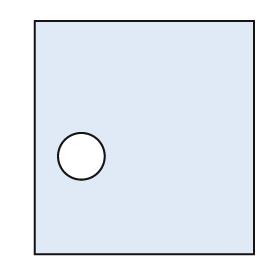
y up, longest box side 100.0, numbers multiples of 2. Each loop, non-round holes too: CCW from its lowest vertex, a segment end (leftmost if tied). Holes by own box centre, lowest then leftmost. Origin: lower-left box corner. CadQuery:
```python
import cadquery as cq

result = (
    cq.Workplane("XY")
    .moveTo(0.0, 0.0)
    .lineTo(94.0, 0.0)
    .lineTo(94.0, 100.0)
    .lineTo(0.0, 100.0)
    .close()
    .moveTo(20.0, 42.0)
    .circle(10.0)
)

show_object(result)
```